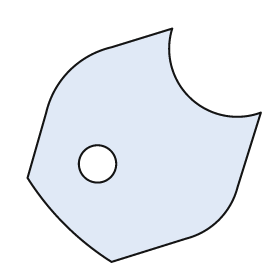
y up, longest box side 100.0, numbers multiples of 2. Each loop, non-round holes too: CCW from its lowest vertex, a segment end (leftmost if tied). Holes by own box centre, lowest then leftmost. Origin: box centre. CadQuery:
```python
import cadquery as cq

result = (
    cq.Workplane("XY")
    .moveTo(-14.0, -50.0)
    .lineTo(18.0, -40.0)
    .threePointArc((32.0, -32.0), (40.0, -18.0))
    .lineTo(50.0, 14.0)
    .threePointArc((20.0, 20.0), (12.0, 50.0))
    .lineTo(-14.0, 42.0)
    .threePointArc((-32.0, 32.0), (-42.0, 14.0))
    .lineTo(-50.0, -14.0)
    .threePointArc((-34.0, -34.0), (-14.0, -50.0))
    .close()
    .moveTo(-20.0, -8.0)
    .circle(8.0)
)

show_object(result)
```